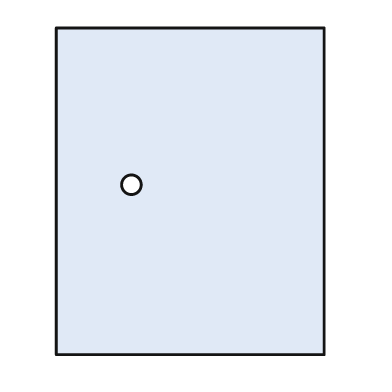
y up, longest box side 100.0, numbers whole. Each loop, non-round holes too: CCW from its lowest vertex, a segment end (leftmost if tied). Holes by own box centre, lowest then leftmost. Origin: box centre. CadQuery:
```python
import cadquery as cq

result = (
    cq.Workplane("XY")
    .moveTo(-41.0, -50.0)
    .lineTo(41.0, -50.0)
    .lineTo(41.0, 50.0)
    .lineTo(-41.0, 50.0)
    .close()
    .moveTo(-18.0, 2.0)
    .circle(3.0)
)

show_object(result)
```